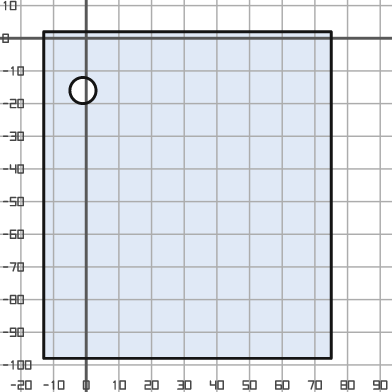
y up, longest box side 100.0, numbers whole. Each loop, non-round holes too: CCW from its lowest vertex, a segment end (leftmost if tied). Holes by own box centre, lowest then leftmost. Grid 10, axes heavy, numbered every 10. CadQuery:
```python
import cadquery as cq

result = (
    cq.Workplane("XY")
    .moveTo(-13.0, -98.0)
    .lineTo(75.0, -98.0)
    .lineTo(75.0, 2.0)
    .lineTo(-13.0, 2.0)
    .close()
    .moveTo(-1.0, -16.0)
    .circle(4.0)
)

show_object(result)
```